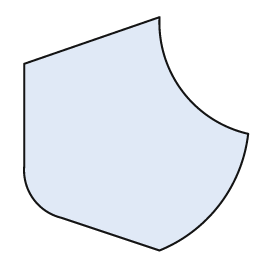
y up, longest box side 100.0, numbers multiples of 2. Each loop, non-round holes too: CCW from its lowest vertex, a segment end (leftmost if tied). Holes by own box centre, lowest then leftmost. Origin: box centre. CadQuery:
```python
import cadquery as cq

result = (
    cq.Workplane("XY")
    .moveTo(10.0, -50.0)
    .threePointArc((36.0, -30.0), (48.0, 0.0))
    .threePointArc((20.0, 18.0), (10.0, 50.0))
    .lineTo(-48.0, 30.0)
    .lineTo(-48.0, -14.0)
    .threePointArc((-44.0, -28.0), (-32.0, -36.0))
    .close()
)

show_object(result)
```